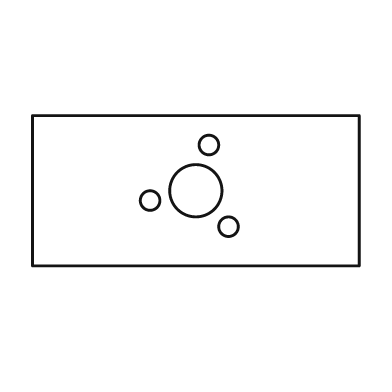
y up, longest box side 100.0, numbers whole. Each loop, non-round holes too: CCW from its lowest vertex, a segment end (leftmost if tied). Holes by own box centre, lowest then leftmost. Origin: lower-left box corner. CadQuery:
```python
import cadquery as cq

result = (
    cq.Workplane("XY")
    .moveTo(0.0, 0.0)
    .lineTo(100.0, 0.0)
    .lineTo(100.0, 46.0)
    .lineTo(0.0, 46.0)
    .close()
    .moveTo(60.0, 12.0)
    .circle(3.0)
    .moveTo(36.0, 20.0)
    .circle(3.0)
    .moveTo(50.0, 23.0)
    .circle(8.0)
    .moveTo(54.0, 37.0)
    .circle(3.0)
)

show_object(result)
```